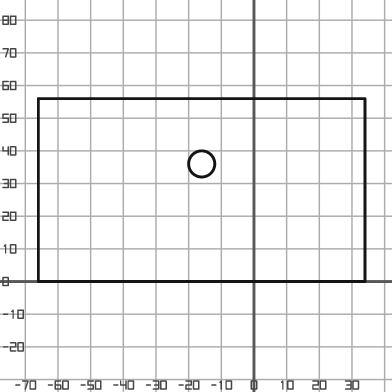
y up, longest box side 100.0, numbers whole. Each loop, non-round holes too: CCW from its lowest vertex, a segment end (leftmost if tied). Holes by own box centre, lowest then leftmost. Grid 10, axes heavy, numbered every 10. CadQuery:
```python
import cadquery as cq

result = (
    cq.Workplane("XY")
    .moveTo(-66.0, 0.0)
    .lineTo(34.0, 0.0)
    .lineTo(34.0, 56.0)
    .lineTo(-66.0, 56.0)
    .close()
    .moveTo(-16.0, 36.0)
    .circle(4.0)
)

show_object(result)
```